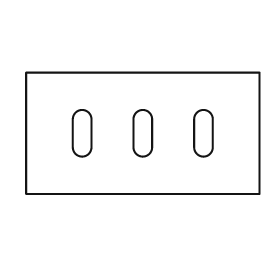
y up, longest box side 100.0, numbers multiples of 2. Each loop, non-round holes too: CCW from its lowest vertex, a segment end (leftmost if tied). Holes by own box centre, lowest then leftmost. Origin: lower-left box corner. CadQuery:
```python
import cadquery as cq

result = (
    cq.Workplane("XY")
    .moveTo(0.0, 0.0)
    .lineTo(100.0, 0.0)
    .lineTo(100.0, 52.0)
    .lineTo(0.0, 52.0)
    .close()
    .moveTo(20.0, 20.0)
    .threePointArc((24.0, 16.0), (28.0, 20.0))
    .lineTo(28.0, 32.0)
    .threePointArc((24.0, 36.0), (20.0, 32.0))
    .close()
    .moveTo(46.0, 20.0)
    .threePointArc((50.0, 16.0), (54.0, 20.0))
    .lineTo(54.0, 32.0)
    .threePointArc((50.0, 36.0), (46.0, 32.0))
    .close()
    .moveTo(72.0, 20.0)
    .threePointArc((76.0, 16.0), (80.0, 20.0))
    .lineTo(80.0, 32.0)
    .threePointArc((76.0, 36.0), (72.0, 32.0))
    .close()
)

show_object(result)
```